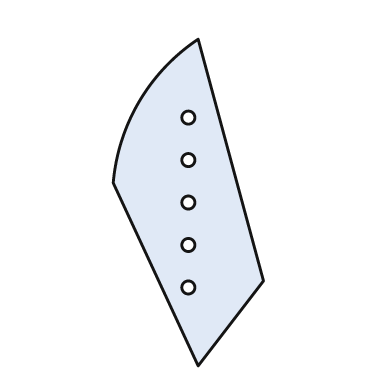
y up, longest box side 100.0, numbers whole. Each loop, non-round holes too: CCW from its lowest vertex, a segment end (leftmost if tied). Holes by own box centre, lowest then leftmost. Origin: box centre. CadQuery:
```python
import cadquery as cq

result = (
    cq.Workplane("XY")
    .moveTo(3.0, -50.0)
    .lineTo(23.0, -24.0)
    .lineTo(3.0, 50.0)
    .threePointArc((-15.0, 31.0), (-23.0, 6.0))
    .close()
    .moveTo(0.0, -26.0)
    .circle(2.0)
    .moveTo(0.0, -13.0)
    .circle(2.0)
    .moveTo(0.0, 0.0)
    .circle(2.0)
    .moveTo(0.0, 13.0)
    .circle(2.0)
    .moveTo(0.0, 26.0)
    .circle(2.0)
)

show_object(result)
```